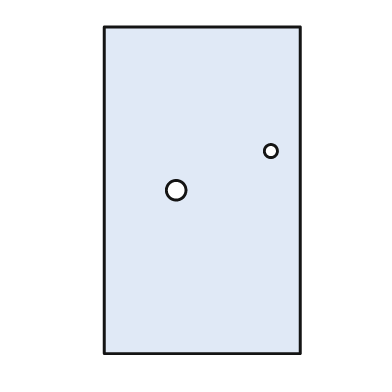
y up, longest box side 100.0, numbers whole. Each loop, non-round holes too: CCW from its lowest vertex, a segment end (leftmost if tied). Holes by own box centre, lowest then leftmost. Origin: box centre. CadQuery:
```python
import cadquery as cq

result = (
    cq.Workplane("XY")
    .moveTo(-30.0, -50.0)
    .lineTo(30.0, -50.0)
    .lineTo(30.0, 50.0)
    .lineTo(-30.0, 50.0)
    .close()
    .moveTo(-8.0, 0.0)
    .circle(3.0)
    .moveTo(21.0, 12.0)
    .circle(2.0)
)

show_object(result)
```